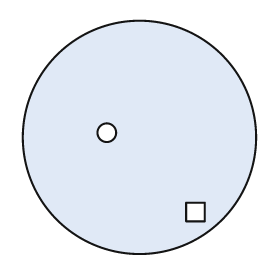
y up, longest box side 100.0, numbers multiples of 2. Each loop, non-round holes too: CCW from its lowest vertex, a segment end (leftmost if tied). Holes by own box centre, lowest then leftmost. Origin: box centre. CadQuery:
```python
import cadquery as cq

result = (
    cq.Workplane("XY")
    .moveTo(0.0, 0.0)
    .circle(50.0)
    .moveTo(20.0, -36.0)
    .lineTo(28.0, -36.0)
    .lineTo(28.0, -28.0)
    .lineTo(20.0, -28.0)
    .close()
    .moveTo(-14.0, 2.0)
    .circle(4.0)
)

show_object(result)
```